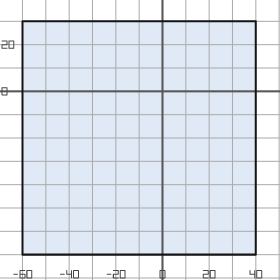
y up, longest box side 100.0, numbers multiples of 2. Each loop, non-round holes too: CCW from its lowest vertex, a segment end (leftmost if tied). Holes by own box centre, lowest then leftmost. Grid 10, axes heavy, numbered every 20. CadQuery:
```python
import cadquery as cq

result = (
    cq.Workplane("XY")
    .moveTo(-60.0, -70.0)
    .lineTo(40.0, -70.0)
    .lineTo(40.0, 30.0)
    .lineTo(-60.0, 30.0)
    .close()
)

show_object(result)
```